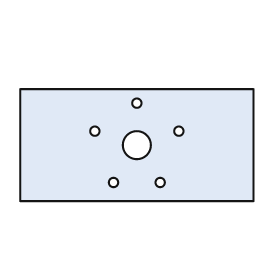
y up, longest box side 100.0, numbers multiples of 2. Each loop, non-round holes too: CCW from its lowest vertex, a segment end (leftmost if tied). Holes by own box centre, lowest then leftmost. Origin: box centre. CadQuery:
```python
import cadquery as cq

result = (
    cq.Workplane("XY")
    .moveTo(-50.0, -24.0)
    .lineTo(50.0, -24.0)
    .lineTo(50.0, 24.0)
    .lineTo(-50.0, 24.0)
    .close()
    .moveTo(-10.0, -16.0)
    .circle(2.0)
    .moveTo(10.0, -16.0)
    .circle(2.0)
    .moveTo(0.0, 0.0)
    .circle(6.0)
    .moveTo(-18.0, 6.0)
    .circle(2.0)
    .moveTo(18.0, 6.0)
    .circle(2.0)
    .moveTo(0.0, 18.0)
    .circle(2.0)
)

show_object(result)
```